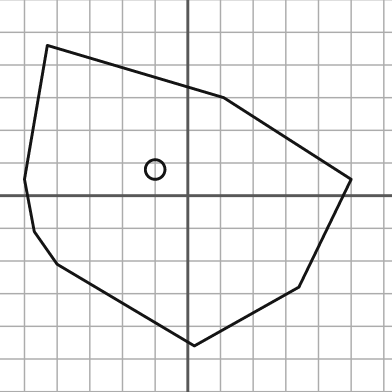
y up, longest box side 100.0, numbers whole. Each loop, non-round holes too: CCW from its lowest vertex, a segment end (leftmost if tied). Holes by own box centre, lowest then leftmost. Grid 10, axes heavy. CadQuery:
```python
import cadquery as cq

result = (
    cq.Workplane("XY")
    .moveTo(2.0, -46.0)
    .lineTo(34.0, -28.0)
    .lineTo(50.0, 5.0)
    .lineTo(11.0, 30.0)
    .lineTo(-43.0, 46.0)
    .lineTo(-50.0, 5.0)
    .lineTo(-47.0, -11.0)
    .lineTo(-40.0, -21.0)
    .close()
    .moveTo(-10.0, 8.0)
    .circle(3.0)
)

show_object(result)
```